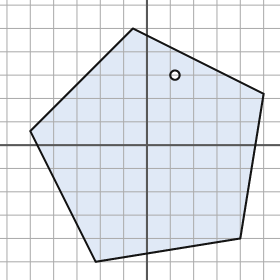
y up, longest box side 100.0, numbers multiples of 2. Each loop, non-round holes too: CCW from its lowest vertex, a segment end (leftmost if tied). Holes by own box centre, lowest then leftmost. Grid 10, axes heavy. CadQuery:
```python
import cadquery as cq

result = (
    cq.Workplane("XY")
    .moveTo(-22.0, -50.0)
    .lineTo(40.0, -40.0)
    .lineTo(50.0, 22.0)
    .lineTo(-6.0, 50.0)
    .lineTo(-50.0, 6.0)
    .close()
    .moveTo(12.0, 30.0)
    .circle(2.0)
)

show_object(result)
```